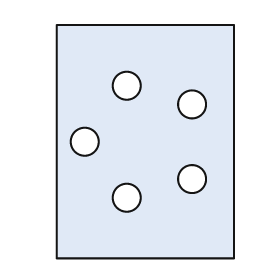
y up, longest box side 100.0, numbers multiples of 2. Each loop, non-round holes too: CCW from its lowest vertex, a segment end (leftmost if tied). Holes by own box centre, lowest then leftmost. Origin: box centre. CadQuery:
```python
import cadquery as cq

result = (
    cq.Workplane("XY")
    .moveTo(-38.0, -50.0)
    .lineTo(38.0, -50.0)
    .lineTo(38.0, 50.0)
    .lineTo(-38.0, 50.0)
    .close()
    .moveTo(-8.0, -24.0)
    .circle(6.0)
    .moveTo(20.0, -16.0)
    .circle(6.0)
    .moveTo(-26.0, 0.0)
    .circle(6.0)
    .moveTo(20.0, 16.0)
    .circle(6.0)
    .moveTo(-8.0, 24.0)
    .circle(6.0)
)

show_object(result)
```